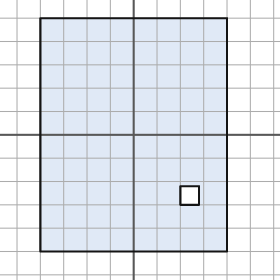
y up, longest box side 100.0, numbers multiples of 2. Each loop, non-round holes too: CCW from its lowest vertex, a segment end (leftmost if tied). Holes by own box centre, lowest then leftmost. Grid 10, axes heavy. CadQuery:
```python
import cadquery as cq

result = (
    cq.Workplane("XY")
    .moveTo(-40.0, -50.0)
    .lineTo(40.0, -50.0)
    .lineTo(40.0, 50.0)
    .lineTo(-40.0, 50.0)
    .close()
    .moveTo(20.0, -30.0)
    .lineTo(28.0, -30.0)
    .lineTo(28.0, -22.0)
    .lineTo(20.0, -22.0)
    .close()
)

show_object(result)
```